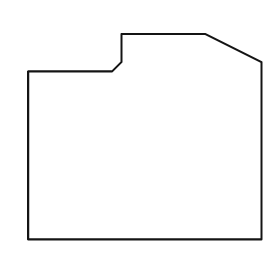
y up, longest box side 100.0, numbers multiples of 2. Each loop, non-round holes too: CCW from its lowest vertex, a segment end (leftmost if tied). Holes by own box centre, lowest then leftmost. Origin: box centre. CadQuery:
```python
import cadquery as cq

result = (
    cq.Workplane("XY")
    .moveTo(-50.0, -44.0)
    .lineTo(50.0, -44.0)
    .lineTo(50.0, 32.0)
    .lineTo(26.0, 44.0)
    .lineTo(-10.0, 44.0)
    .lineTo(-10.0, 32.0)
    .lineTo(-14.0, 28.0)
    .lineTo(-50.0, 28.0)
    .close()
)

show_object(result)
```